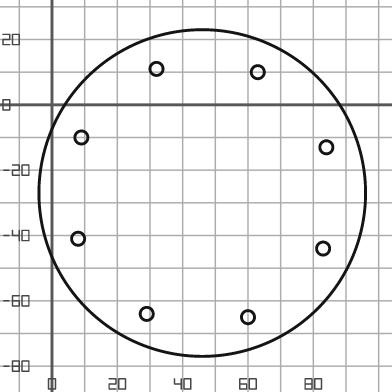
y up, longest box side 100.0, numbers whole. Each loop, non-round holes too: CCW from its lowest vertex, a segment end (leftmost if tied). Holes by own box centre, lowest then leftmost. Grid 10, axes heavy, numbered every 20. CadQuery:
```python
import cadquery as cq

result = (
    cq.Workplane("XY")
    .moveTo(46.0, -27.0)
    .circle(50.0)
    .moveTo(60.0, -65.0)
    .circle(2.0)
    .moveTo(29.0, -64.0)
    .circle(2.0)
    .moveTo(83.0, -44.0)
    .circle(2.0)
    .moveTo(8.0, -41.0)
    .circle(2.0)
    .moveTo(84.0, -13.0)
    .circle(2.0)
    .moveTo(9.0, -10.0)
    .circle(2.0)
    .moveTo(63.0, 10.0)
    .circle(2.0)
    .moveTo(32.0, 11.0)
    .circle(2.0)
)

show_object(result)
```